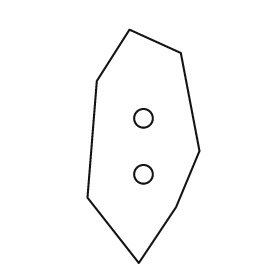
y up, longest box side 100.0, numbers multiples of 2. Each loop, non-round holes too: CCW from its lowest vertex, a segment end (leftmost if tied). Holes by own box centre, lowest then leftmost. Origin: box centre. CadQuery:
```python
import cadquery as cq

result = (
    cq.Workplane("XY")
    .moveTo(-2.0, -50.0)
    .lineTo(14.0, -26.0)
    .lineTo(24.0, -2.0)
    .lineTo(16.0, 40.0)
    .lineTo(-6.0, 50.0)
    .lineTo(-20.0, 28.0)
    .lineTo(-24.0, -22.0)
    .close()
    .moveTo(0.0, -12.0)
    .circle(4.0)
    .moveTo(0.0, 12.0)
    .circle(4.0)
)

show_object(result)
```